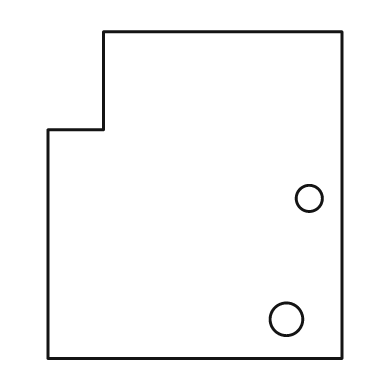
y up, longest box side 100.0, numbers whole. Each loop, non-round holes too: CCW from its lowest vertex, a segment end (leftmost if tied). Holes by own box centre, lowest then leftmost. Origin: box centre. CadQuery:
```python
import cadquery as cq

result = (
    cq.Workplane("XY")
    .moveTo(-45.0, -50.0)
    .lineTo(45.0, -50.0)
    .lineTo(45.0, 50.0)
    .lineTo(-28.0, 50.0)
    .lineTo(-28.0, 20.0)
    .lineTo(-45.0, 20.0)
    .close()
    .moveTo(28.0, -38.0)
    .circle(5.0)
    .moveTo(35.0, -1.0)
    .circle(4.0)
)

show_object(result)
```